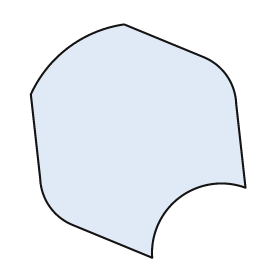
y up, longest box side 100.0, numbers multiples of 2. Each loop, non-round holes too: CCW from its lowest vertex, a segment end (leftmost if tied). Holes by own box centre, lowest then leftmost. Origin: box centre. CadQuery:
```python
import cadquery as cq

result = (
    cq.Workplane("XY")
    .moveTo(6.0, -50.0)
    .threePointArc((18.0, -24.0), (46.0, -20.0))
    .lineTo(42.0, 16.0)
    .threePointArc((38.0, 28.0), (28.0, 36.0))
    .lineTo(-6.0, 50.0)
    .threePointArc((-30.0, 40.0), (-46.0, 20.0))
    .lineTo(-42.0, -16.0)
    .threePointArc((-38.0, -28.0), (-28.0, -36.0))
    .close()
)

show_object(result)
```